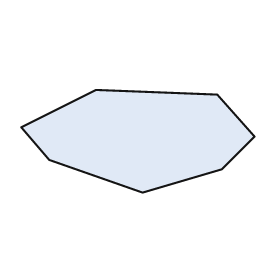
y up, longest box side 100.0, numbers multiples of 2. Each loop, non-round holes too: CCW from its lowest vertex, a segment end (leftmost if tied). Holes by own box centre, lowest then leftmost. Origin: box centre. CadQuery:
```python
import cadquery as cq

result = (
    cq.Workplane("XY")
    .moveTo(2.0, -22.0)
    .lineTo(36.0, -12.0)
    .lineTo(50.0, 2.0)
    .lineTo(34.0, 20.0)
    .lineTo(-18.0, 22.0)
    .lineTo(-50.0, 6.0)
    .lineTo(-38.0, -8.0)
    .close()
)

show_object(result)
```